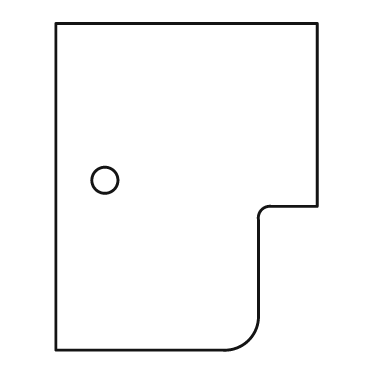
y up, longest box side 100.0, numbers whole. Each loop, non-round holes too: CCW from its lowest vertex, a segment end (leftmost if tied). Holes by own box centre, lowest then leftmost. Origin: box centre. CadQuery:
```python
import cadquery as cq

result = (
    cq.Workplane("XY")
    .moveTo(-40.0, -50.0)
    .lineTo(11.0, -50.0)
    .threePointArc((19.0, -47.0), (22.0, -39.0))
    .lineTo(22.0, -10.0)
    .threePointArc((23.0, -7.0), (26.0, -6.0))
    .lineTo(40.0, -6.0)
    .lineTo(40.0, 50.0)
    .lineTo(-40.0, 50.0)
    .close()
    .moveTo(-25.0, 2.0)
    .circle(4.0)
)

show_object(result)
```